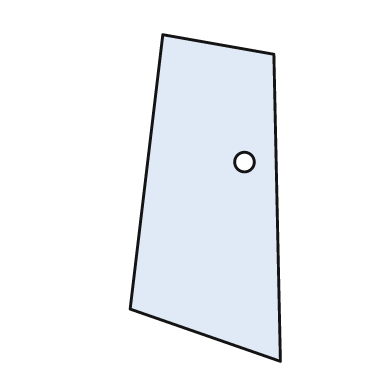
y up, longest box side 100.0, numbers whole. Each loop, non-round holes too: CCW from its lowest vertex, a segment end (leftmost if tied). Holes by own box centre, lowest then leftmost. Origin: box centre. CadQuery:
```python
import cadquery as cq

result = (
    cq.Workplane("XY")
    .moveTo(23.0, -50.0)
    .lineTo(21.0, 44.0)
    .lineTo(-13.0, 50.0)
    .lineTo(-23.0, -34.0)
    .close()
    .moveTo(12.0, 11.0)
    .circle(3.0)
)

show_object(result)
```